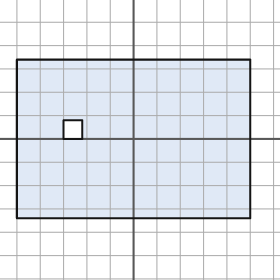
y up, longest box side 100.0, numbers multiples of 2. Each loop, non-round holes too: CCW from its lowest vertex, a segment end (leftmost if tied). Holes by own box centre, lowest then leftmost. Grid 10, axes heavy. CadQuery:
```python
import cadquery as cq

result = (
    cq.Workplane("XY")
    .moveTo(-50.0, -34.0)
    .lineTo(50.0, -34.0)
    .lineTo(50.0, 34.0)
    .lineTo(-50.0, 34.0)
    .close()
    .moveTo(-30.0, 0.0)
    .lineTo(-22.0, 0.0)
    .lineTo(-22.0, 8.0)
    .lineTo(-30.0, 8.0)
    .close()
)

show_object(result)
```